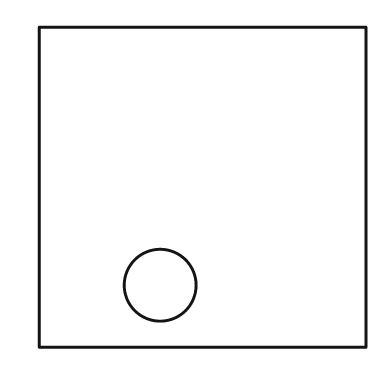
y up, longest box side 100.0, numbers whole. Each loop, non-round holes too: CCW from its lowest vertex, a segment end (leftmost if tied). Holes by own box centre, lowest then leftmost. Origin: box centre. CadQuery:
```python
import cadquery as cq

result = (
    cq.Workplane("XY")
    .moveTo(-50.0, -49.0)
    .lineTo(50.0, -49.0)
    .lineTo(50.0, 49.0)
    .lineTo(-50.0, 49.0)
    .close()
    .moveTo(-13.0, -30.0)
    .circle(11.0)
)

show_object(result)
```